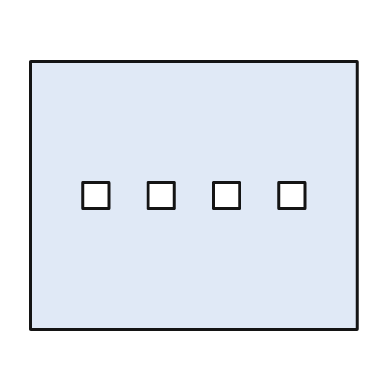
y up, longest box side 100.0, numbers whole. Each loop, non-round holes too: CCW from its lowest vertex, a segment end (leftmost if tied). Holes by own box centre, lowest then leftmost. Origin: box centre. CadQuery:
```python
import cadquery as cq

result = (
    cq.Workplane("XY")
    .moveTo(-50.0, -41.0)
    .lineTo(50.0, -41.0)
    .lineTo(50.0, 41.0)
    .lineTo(-50.0, 41.0)
    .close()
    .moveTo(-34.0, -4.0)
    .lineTo(-26.0, -4.0)
    .lineTo(-26.0, 4.0)
    .lineTo(-34.0, 4.0)
    .close()
    .moveTo(-14.0, -4.0)
    .lineTo(-6.0, -4.0)
    .lineTo(-6.0, 4.0)
    .lineTo(-14.0, 4.0)
    .close()
    .moveTo(6.0, -4.0)
    .lineTo(14.0, -4.0)
    .lineTo(14.0, 4.0)
    .lineTo(6.0, 4.0)
    .close()
    .moveTo(26.0, -4.0)
    .lineTo(34.0, -4.0)
    .lineTo(34.0, 4.0)
    .lineTo(26.0, 4.0)
    .close()
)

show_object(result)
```